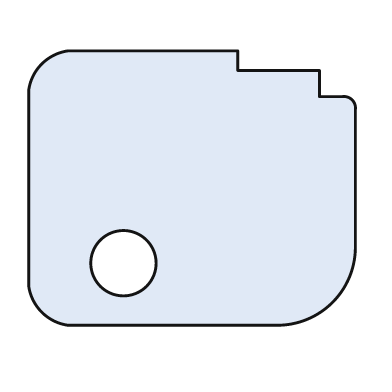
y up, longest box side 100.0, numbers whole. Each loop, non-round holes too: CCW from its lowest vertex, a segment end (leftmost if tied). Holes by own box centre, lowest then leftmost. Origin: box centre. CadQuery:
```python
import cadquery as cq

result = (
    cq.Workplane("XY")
    .moveTo(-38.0, -42.0)
    .lineTo(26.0, -42.0)
    .threePointArc((43.0, -35.0), (50.0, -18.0))
    .lineTo(50.0, 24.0)
    .threePointArc((49.0, 27.0), (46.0, 28.0))
    .lineTo(39.0, 28.0)
    .lineTo(39.0, 36.0)
    .lineTo(14.0, 36.0)
    .lineTo(14.0, 42.0)
    .lineTo(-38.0, 42.0)
    .threePointArc((-46.0, 38.0), (-50.0, 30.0))
    .lineTo(-50.0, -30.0)
    .threePointArc((-46.0, -38.0), (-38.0, -42.0))
    .close()
    .moveTo(-21.0, -23.0)
    .circle(10.0)
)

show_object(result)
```